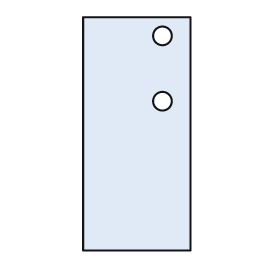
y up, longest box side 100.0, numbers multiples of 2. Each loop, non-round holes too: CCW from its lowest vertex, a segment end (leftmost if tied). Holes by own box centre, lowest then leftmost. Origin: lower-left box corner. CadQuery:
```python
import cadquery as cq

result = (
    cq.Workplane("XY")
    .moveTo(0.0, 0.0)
    .lineTo(46.0, 0.0)
    .lineTo(46.0, 100.0)
    .lineTo(0.0, 100.0)
    .close()
    .moveTo(34.0, 64.0)
    .circle(4.0)
    .moveTo(34.0, 92.0)
    .circle(4.0)
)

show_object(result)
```